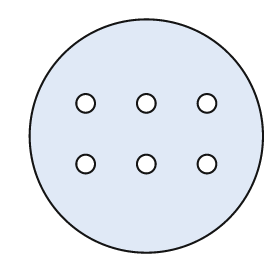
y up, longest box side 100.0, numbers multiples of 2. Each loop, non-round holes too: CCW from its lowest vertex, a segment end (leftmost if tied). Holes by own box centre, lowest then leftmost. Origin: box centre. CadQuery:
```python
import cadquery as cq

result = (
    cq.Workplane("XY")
    .moveTo(0.0, 0.0)
    .circle(50.0)
    .moveTo(-26.0, -12.0)
    .circle(4.0)
    .moveTo(0.0, -12.0)
    .circle(4.0)
    .moveTo(26.0, -12.0)
    .circle(4.0)
    .moveTo(-26.0, 14.0)
    .circle(4.0)
    .moveTo(0.0, 14.0)
    .circle(4.0)
    .moveTo(26.0, 14.0)
    .circle(4.0)
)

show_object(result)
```